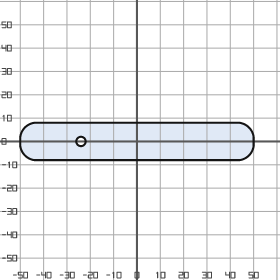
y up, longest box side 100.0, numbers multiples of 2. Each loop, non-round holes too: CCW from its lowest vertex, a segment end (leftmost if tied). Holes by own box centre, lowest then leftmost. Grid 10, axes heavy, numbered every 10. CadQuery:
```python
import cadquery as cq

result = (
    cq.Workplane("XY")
    .moveTo(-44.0, -8.0)
    .lineTo(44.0, -8.0)
    .threePointArc((48.0, -6.0), (50.0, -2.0))
    .lineTo(50.0, 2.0)
    .threePointArc((48.0, 6.0), (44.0, 8.0))
    .lineTo(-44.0, 8.0)
    .threePointArc((-48.0, 6.0), (-50.0, 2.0))
    .lineTo(-50.0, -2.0)
    .threePointArc((-48.0, -6.0), (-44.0, -8.0))
    .close()
    .moveTo(-24.0, 0.0)
    .circle(2.0)
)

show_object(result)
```